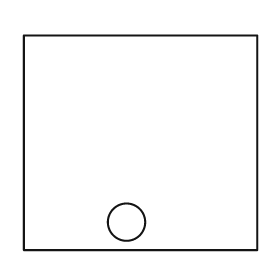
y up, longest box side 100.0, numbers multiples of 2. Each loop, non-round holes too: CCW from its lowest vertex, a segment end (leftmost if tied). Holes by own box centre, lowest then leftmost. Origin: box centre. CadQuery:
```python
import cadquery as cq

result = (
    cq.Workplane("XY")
    .moveTo(-50.0, -46.0)
    .lineTo(50.0, -46.0)
    .lineTo(50.0, 46.0)
    .lineTo(-50.0, 46.0)
    .close()
    .moveTo(-6.0, -34.0)
    .circle(8.0)
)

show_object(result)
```